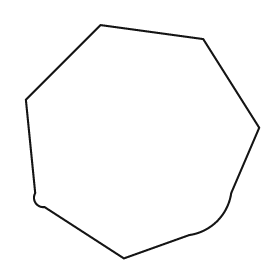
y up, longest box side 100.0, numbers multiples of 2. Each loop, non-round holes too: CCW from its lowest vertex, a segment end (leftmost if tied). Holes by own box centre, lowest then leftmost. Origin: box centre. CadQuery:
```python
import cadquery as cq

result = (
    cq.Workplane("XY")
    .moveTo(-8.0, -50.0)
    .lineTo(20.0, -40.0)
    .threePointArc((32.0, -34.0), (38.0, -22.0))
    .lineTo(50.0, 6.0)
    .lineTo(26.0, 44.0)
    .lineTo(-18.0, 50.0)
    .lineTo(-50.0, 18.0)
    .lineTo(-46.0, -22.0)
    .threePointArc((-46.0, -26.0), (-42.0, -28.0))
    .close()
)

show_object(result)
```